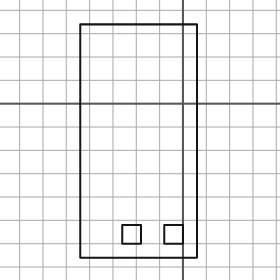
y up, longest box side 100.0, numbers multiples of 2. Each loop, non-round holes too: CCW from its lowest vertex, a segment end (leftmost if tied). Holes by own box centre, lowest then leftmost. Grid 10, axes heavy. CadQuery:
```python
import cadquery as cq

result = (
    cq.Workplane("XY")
    .moveTo(-44.0, -66.0)
    .lineTo(6.0, -66.0)
    .lineTo(6.0, 34.0)
    .lineTo(-44.0, 34.0)
    .close()
    .moveTo(-26.0, -60.0)
    .lineTo(-18.0, -60.0)
    .lineTo(-18.0, -52.0)
    .lineTo(-26.0, -52.0)
    .close()
    .moveTo(-8.0, -60.0)
    .lineTo(0.0, -60.0)
    .lineTo(0.0, -52.0)
    .lineTo(-8.0, -52.0)
    .close()
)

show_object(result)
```